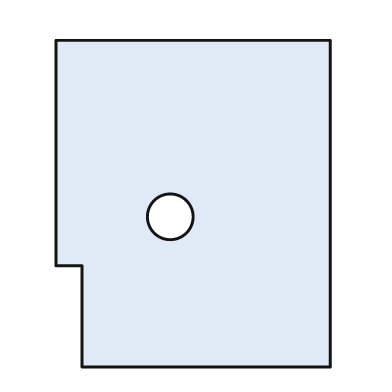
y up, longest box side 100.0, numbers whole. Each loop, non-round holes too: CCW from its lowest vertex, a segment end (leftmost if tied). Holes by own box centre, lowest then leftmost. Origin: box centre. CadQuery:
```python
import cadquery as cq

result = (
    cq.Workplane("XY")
    .moveTo(-34.0, -50.0)
    .lineTo(42.0, -50.0)
    .lineTo(42.0, 50.0)
    .lineTo(-42.0, 50.0)
    .lineTo(-42.0, -19.0)
    .lineTo(-34.0, -19.0)
    .close()
    .moveTo(-7.0, -4.0)
    .circle(7.0)
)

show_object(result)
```